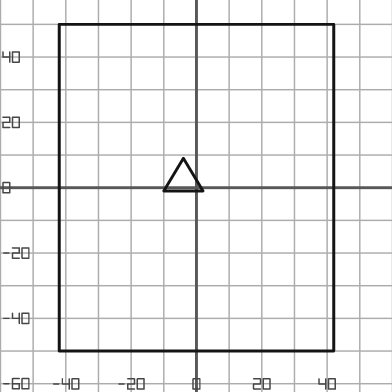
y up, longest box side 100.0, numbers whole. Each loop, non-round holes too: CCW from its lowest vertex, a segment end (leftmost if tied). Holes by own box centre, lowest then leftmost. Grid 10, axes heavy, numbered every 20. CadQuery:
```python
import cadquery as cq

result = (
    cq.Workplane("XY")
    .moveTo(-42.0, -50.0)
    .lineTo(42.0, -50.0)
    .lineTo(42.0, 50.0)
    .lineTo(-42.0, 50.0)
    .close()
    .moveTo(-10.0, -1.0)
    .lineTo(2.0, -1.0)
    .lineTo(-4.0, 9.0)
    .close()
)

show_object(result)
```